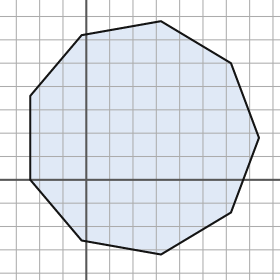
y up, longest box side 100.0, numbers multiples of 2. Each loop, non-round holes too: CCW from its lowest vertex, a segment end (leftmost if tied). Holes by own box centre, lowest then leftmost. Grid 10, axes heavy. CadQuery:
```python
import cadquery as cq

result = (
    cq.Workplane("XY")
    .moveTo(32.0, -32.0)
    .lineTo(62.0, -14.0)
    .lineTo(74.0, 18.0)
    .lineTo(62.0, 50.0)
    .lineTo(32.0, 68.0)
    .lineTo(-2.0, 62.0)
    .lineTo(-24.0, 36.0)
    .lineTo(-24.0, 0.0)
    .lineTo(-2.0, -26.0)
    .close()
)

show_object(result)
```